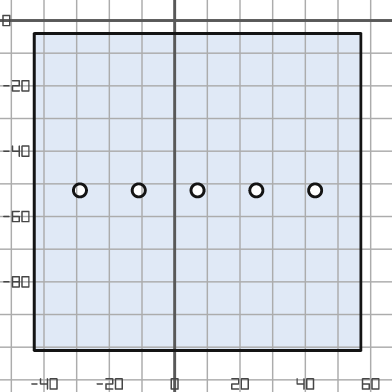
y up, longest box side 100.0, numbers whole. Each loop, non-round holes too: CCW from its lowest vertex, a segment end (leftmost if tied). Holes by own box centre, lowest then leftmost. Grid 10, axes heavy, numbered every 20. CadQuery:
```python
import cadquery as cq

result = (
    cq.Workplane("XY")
    .moveTo(-43.0, -101.0)
    .lineTo(57.0, -101.0)
    .lineTo(57.0, -4.0)
    .lineTo(-43.0, -4.0)
    .close()
    .moveTo(-29.0, -52.0)
    .circle(2.0)
    .moveTo(-11.0, -52.0)
    .circle(2.0)
    .moveTo(7.0, -52.0)
    .circle(2.0)
    .moveTo(25.0, -52.0)
    .circle(2.0)
    .moveTo(43.0, -52.0)
    .circle(2.0)
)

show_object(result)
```